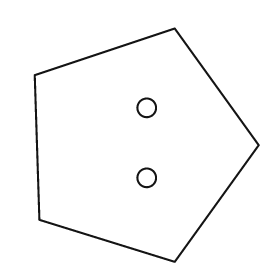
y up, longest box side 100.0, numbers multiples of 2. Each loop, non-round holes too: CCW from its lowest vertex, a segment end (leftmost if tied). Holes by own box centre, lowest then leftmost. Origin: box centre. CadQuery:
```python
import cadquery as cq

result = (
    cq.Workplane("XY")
    .moveTo(12.0, -50.0)
    .lineTo(48.0, 0.0)
    .lineTo(12.0, 50.0)
    .lineTo(-48.0, 30.0)
    .lineTo(-46.0, -32.0)
    .close()
    .moveTo(0.0, -14.0)
    .circle(4.0)
    .moveTo(0.0, 16.0)
    .circle(4.0)
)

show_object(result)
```